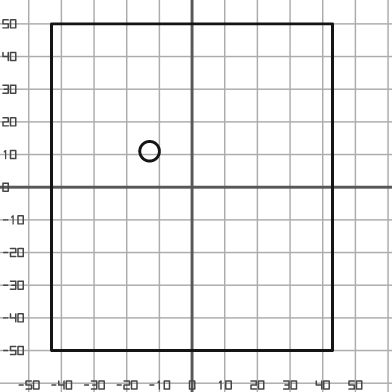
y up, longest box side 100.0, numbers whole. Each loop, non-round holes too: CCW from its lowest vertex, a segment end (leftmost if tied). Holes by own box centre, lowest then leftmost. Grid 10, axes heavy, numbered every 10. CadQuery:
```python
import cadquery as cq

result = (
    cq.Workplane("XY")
    .moveTo(-43.0, -50.0)
    .lineTo(43.0, -50.0)
    .lineTo(43.0, 50.0)
    .lineTo(-43.0, 50.0)
    .close()
    .moveTo(-13.0, 11.0)
    .circle(3.0)
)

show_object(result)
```